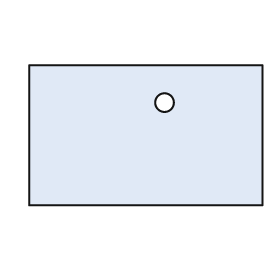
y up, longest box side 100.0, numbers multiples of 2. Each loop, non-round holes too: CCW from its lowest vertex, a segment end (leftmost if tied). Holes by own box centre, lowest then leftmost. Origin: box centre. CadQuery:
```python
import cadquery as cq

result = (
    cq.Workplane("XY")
    .moveTo(-50.0, -30.0)
    .lineTo(50.0, -30.0)
    .lineTo(50.0, 30.0)
    .lineTo(-50.0, 30.0)
    .close()
    .moveTo(8.0, 14.0)
    .circle(4.0)
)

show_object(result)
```